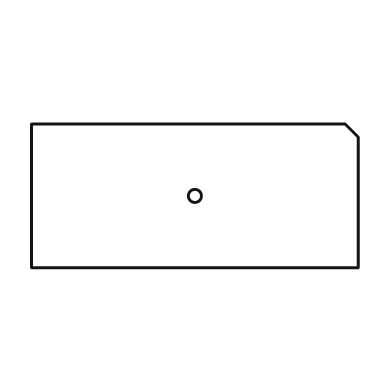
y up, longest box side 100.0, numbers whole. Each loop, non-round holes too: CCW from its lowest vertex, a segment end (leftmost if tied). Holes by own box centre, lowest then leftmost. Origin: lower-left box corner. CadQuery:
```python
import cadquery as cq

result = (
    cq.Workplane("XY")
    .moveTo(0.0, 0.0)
    .lineTo(100.0, 0.0)
    .lineTo(100.0, 40.0)
    .lineTo(96.0, 44.0)
    .lineTo(0.0, 44.0)
    .close()
    .moveTo(50.0, 22.0)
    .circle(2.0)
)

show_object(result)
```